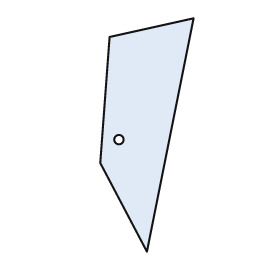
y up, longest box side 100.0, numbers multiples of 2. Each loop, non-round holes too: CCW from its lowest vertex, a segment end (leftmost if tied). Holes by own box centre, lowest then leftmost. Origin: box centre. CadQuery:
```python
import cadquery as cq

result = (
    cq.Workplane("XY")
    .moveTo(0.0, -50.0)
    .lineTo(20.0, 50.0)
    .lineTo(-16.0, 42.0)
    .lineTo(-20.0, -12.0)
    .close()
    .moveTo(-12.0, -2.0)
    .circle(2.0)
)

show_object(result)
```